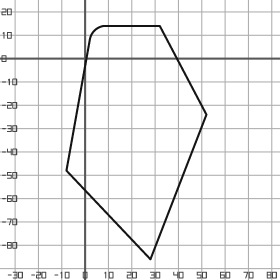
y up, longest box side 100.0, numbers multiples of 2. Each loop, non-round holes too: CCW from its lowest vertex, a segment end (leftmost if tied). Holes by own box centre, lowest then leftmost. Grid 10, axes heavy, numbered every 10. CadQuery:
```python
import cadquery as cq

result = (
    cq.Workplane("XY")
    .moveTo(28.0, -86.0)
    .lineTo(52.0, -24.0)
    .lineTo(32.0, 14.0)
    .lineTo(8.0, 14.0)
    .threePointArc((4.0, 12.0), (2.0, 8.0))
    .lineTo(-8.0, -48.0)
    .close()
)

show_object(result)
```